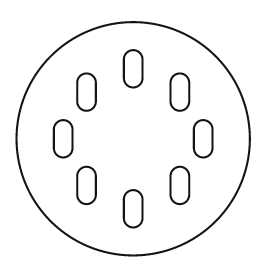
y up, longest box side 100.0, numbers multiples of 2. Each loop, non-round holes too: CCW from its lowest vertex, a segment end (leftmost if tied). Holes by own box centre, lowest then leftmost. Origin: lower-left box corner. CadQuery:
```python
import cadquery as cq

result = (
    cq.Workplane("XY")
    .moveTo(50.0, 50.0)
    .circle(50.0)
    .moveTo(46.0, 16.0)
    .threePointArc((50.0, 12.0), (54.0, 16.0))
    .lineTo(54.0, 24.0)
    .threePointArc((50.0, 28.0), (46.0, 24.0))
    .close()
    .moveTo(26.0, 26.0)
    .threePointArc((30.0, 22.0), (34.0, 26.0))
    .lineTo(34.0, 34.0)
    .threePointArc((30.0, 38.0), (26.0, 34.0))
    .close()
    .moveTo(66.0, 26.0)
    .threePointArc((70.0, 22.0), (74.0, 26.0))
    .lineTo(74.0, 34.0)
    .threePointArc((70.0, 38.0), (66.0, 34.0))
    .close()
    .moveTo(16.0, 46.0)
    .threePointArc((20.0, 42.0), (24.0, 46.0))
    .lineTo(24.0, 54.0)
    .threePointArc((20.0, 58.0), (16.0, 54.0))
    .close()
    .moveTo(76.0, 46.0)
    .threePointArc((80.0, 42.0), (84.0, 46.0))
    .lineTo(84.0, 54.0)
    .threePointArc((80.0, 58.0), (76.0, 54.0))
    .close()
    .moveTo(26.0, 66.0)
    .threePointArc((30.0, 62.0), (34.0, 66.0))
    .lineTo(34.0, 74.0)
    .threePointArc((30.0, 78.0), (26.0, 74.0))
    .close()
    .moveTo(66.0, 66.0)
    .threePointArc((70.0, 62.0), (74.0, 66.0))
    .lineTo(74.0, 74.0)
    .threePointArc((70.0, 78.0), (66.0, 74.0))
    .close()
    .moveTo(46.0, 76.0)
    .threePointArc((50.0, 72.0), (54.0, 76.0))
    .lineTo(54.0, 84.0)
    .threePointArc((50.0, 88.0), (46.0, 84.0))
    .close()
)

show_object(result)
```